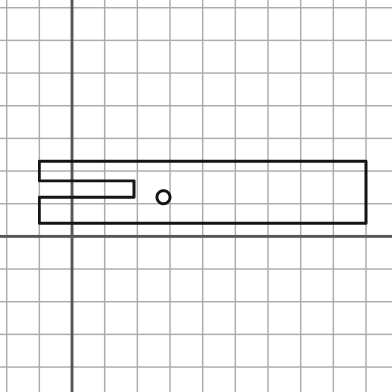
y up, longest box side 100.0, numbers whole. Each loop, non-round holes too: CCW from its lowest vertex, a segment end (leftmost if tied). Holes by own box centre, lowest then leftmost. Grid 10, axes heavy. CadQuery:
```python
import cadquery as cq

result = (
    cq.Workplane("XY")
    .moveTo(-10.0, 4.0)
    .lineTo(90.0, 4.0)
    .lineTo(90.0, 23.0)
    .lineTo(-10.0, 23.0)
    .lineTo(-10.0, 17.0)
    .lineTo(19.0, 17.0)
    .lineTo(19.0, 12.0)
    .lineTo(-10.0, 12.0)
    .close()
    .moveTo(28.0, 12.0)
    .circle(2.0)
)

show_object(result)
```